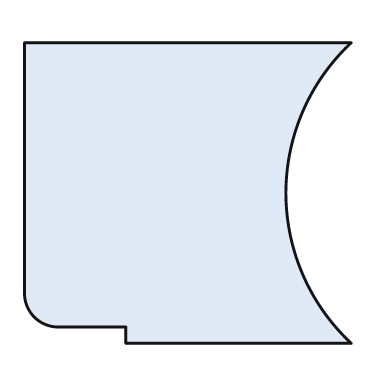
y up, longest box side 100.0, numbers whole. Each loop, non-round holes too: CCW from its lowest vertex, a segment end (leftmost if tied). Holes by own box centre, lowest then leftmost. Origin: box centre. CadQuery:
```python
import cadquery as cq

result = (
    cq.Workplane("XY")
    .moveTo(-19.0, -46.0)
    .lineTo(50.0, -46.0)
    .threePointArc((30.0, 0.0), (50.0, 46.0))
    .lineTo(-50.0, 46.0)
    .lineTo(-50.0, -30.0)
    .threePointArc((-47.0, -38.0), (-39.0, -41.0))
    .lineTo(-19.0, -41.0)
    .close()
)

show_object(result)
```